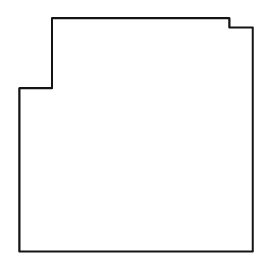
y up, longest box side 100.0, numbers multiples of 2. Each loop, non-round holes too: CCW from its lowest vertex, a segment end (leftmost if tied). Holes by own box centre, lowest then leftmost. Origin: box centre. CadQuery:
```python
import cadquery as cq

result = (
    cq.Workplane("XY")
    .moveTo(-50.0, -50.0)
    .lineTo(50.0, -50.0)
    .lineTo(50.0, 46.0)
    .lineTo(40.0, 46.0)
    .lineTo(40.0, 50.0)
    .lineTo(-36.0, 50.0)
    .lineTo(-36.0, 20.0)
    .lineTo(-50.0, 20.0)
    .close()
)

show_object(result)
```